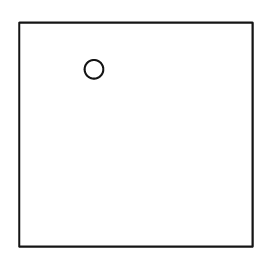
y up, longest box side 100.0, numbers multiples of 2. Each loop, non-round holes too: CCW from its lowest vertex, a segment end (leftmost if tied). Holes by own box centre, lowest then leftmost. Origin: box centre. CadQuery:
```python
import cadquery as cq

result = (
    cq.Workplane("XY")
    .moveTo(-50.0, -48.0)
    .lineTo(50.0, -48.0)
    .lineTo(50.0, 48.0)
    .lineTo(-50.0, 48.0)
    .close()
    .moveTo(-18.0, 28.0)
    .circle(4.0)
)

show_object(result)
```